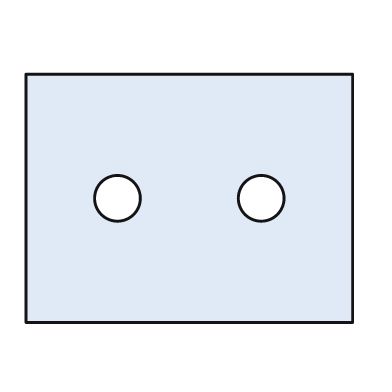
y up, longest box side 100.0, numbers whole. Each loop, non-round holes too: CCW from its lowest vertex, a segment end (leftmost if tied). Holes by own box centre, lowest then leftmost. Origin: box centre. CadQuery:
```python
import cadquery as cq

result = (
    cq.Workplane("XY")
    .moveTo(-50.0, -38.0)
    .lineTo(50.0, -38.0)
    .lineTo(50.0, 38.0)
    .lineTo(-50.0, 38.0)
    .close()
    .moveTo(-22.0, 0.0)
    .circle(7.0)
    .moveTo(22.0, 0.0)
    .circle(7.0)
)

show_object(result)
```